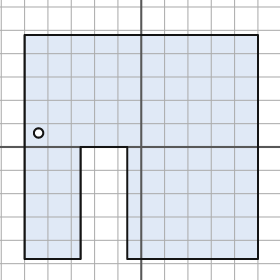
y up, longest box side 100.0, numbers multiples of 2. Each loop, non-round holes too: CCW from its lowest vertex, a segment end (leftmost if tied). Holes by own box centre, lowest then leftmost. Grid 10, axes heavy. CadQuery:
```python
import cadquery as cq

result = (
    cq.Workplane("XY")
    .moveTo(-50.0, -48.0)
    .lineTo(-26.0, -48.0)
    .lineTo(-26.0, 0.0)
    .lineTo(-6.0, 0.0)
    .lineTo(-6.0, -48.0)
    .lineTo(50.0, -48.0)
    .lineTo(50.0, 48.0)
    .lineTo(-50.0, 48.0)
    .close()
    .moveTo(-44.0, 6.0)
    .circle(2.0)
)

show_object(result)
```